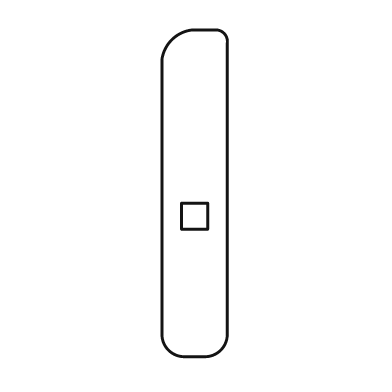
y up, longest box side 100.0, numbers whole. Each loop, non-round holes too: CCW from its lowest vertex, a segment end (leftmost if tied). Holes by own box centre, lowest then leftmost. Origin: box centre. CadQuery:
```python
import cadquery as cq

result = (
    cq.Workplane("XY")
    .moveTo(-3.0, -50.0)
    .lineTo(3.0, -50.0)
    .threePointArc((8.0, -48.0), (10.0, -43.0))
    .lineTo(10.0, 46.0)
    .threePointArc((9.0, 49.0), (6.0, 50.0))
    .lineTo(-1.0, 50.0)
    .threePointArc((-7.0, 47.0), (-10.0, 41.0))
    .lineTo(-10.0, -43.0)
    .threePointArc((-8.0, -48.0), (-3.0, -50.0))
    .close()
    .moveTo(-4.0, -11.0)
    .lineTo(4.0, -11.0)
    .lineTo(4.0, -3.0)
    .lineTo(-4.0, -3.0)
    .close()
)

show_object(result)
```